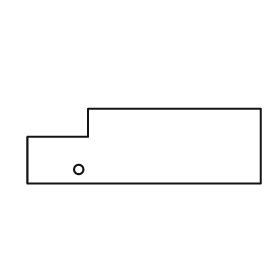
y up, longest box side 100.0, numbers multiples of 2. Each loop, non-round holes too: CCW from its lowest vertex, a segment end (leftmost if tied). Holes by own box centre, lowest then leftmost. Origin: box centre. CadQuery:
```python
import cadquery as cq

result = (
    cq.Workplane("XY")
    .moveTo(-50.0, -16.0)
    .lineTo(50.0, -16.0)
    .lineTo(50.0, 16.0)
    .lineTo(-24.0, 16.0)
    .lineTo(-24.0, 4.0)
    .lineTo(-50.0, 4.0)
    .close()
    .moveTo(-28.0, -10.0)
    .circle(2.0)
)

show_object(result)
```